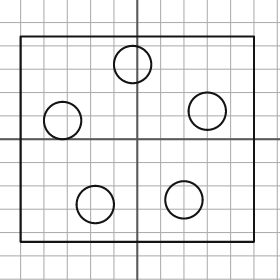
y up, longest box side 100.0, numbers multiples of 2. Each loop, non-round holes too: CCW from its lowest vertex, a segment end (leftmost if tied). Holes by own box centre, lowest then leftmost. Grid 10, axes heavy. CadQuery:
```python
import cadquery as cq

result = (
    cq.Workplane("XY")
    .moveTo(-50.0, -44.0)
    .lineTo(50.0, -44.0)
    .lineTo(50.0, 44.0)
    .lineTo(-50.0, 44.0)
    .close()
    .moveTo(-18.0, -28.0)
    .circle(8.0)
    .moveTo(20.0, -26.0)
    .circle(8.0)
    .moveTo(-32.0, 8.0)
    .circle(8.0)
    .moveTo(30.0, 12.0)
    .circle(8.0)
    .moveTo(-2.0, 32.0)
    .circle(8.0)
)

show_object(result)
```